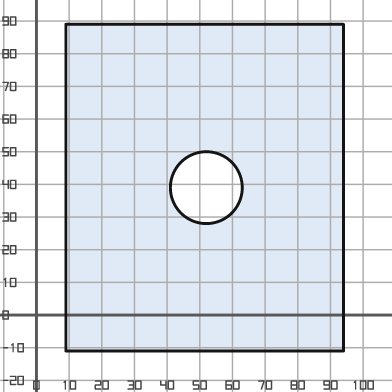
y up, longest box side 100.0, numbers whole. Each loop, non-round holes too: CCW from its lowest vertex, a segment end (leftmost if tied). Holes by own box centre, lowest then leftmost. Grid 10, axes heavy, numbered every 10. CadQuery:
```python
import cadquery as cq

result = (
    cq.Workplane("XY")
    .moveTo(9.0, -11.0)
    .lineTo(94.0, -11.0)
    .lineTo(94.0, 89.0)
    .lineTo(9.0, 89.0)
    .close()
    .moveTo(52.0, 39.0)
    .circle(11.0)
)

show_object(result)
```